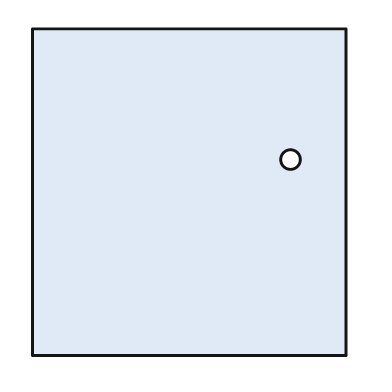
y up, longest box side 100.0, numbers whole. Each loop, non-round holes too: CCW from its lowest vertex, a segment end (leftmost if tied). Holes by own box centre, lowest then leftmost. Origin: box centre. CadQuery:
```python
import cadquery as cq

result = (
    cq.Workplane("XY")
    .moveTo(-48.0, -50.0)
    .lineTo(48.0, -50.0)
    .lineTo(48.0, 50.0)
    .lineTo(-48.0, 50.0)
    .close()
    .moveTo(31.0, 10.0)
    .circle(3.0)
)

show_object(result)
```